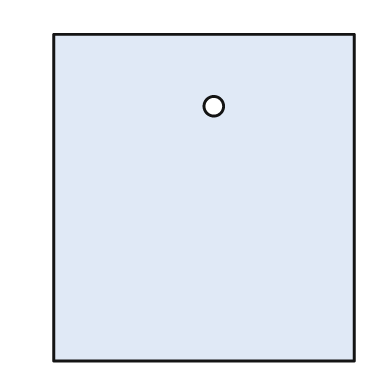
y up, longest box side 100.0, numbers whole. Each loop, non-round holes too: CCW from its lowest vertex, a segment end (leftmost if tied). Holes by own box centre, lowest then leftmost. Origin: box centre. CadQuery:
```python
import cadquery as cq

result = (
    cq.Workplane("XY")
    .moveTo(-46.0, -50.0)
    .lineTo(46.0, -50.0)
    .lineTo(46.0, 50.0)
    .lineTo(-46.0, 50.0)
    .close()
    .moveTo(3.0, 28.0)
    .circle(3.0)
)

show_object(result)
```